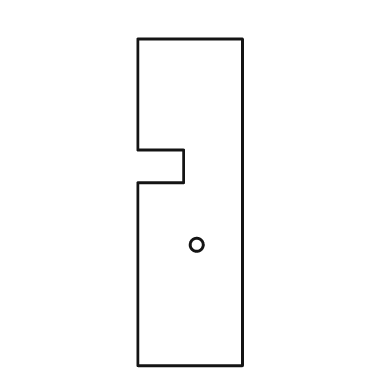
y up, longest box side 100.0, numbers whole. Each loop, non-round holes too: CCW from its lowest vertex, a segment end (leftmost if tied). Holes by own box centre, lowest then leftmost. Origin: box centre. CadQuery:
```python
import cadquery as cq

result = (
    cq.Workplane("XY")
    .moveTo(-16.0, -50.0)
    .lineTo(16.0, -50.0)
    .lineTo(16.0, 50.0)
    .lineTo(-16.0, 50.0)
    .lineTo(-16.0, 16.0)
    .lineTo(-2.0, 16.0)
    .lineTo(-2.0, 6.0)
    .lineTo(-16.0, 6.0)
    .close()
    .moveTo(2.0, -13.0)
    .circle(2.0)
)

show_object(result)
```